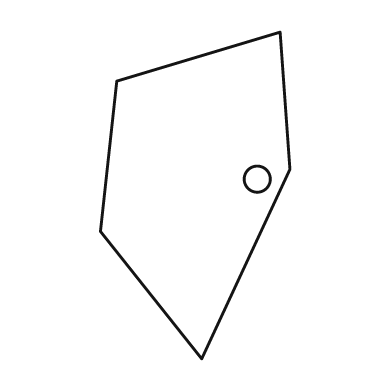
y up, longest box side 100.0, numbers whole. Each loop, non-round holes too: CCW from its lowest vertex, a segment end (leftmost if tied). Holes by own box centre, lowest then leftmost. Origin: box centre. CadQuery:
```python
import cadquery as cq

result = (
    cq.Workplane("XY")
    .moveTo(2.0, -50.0)
    .lineTo(29.0, 8.0)
    .lineTo(26.0, 50.0)
    .lineTo(-24.0, 35.0)
    .lineTo(-29.0, -11.0)
    .close()
    .moveTo(19.0, 5.0)
    .circle(4.0)
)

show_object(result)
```